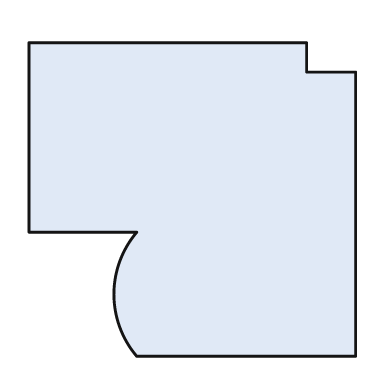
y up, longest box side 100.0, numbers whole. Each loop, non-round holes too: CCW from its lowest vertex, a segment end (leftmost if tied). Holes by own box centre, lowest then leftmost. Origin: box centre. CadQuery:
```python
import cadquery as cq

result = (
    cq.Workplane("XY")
    .moveTo(-17.0, -48.0)
    .lineTo(50.0, -48.0)
    .lineTo(50.0, 39.0)
    .lineTo(35.0, 39.0)
    .lineTo(35.0, 48.0)
    .lineTo(-50.0, 48.0)
    .lineTo(-50.0, -10.0)
    .lineTo(-17.0, -10.0)
    .threePointArc((-24.0, -29.0), (-17.0, -48.0))
    .close()
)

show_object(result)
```